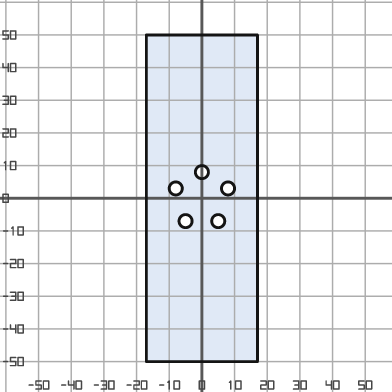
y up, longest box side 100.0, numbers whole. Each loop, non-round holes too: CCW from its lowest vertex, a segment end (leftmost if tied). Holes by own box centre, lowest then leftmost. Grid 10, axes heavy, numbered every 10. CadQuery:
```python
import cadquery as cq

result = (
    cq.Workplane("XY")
    .moveTo(-17.0, -50.0)
    .lineTo(17.0, -50.0)
    .lineTo(17.0, 50.0)
    .lineTo(-17.0, 50.0)
    .close()
    .moveTo(-5.0, -7.0)
    .circle(2.0)
    .moveTo(5.0, -7.0)
    .circle(2.0)
    .moveTo(-8.0, 3.0)
    .circle(2.0)
    .moveTo(8.0, 3.0)
    .circle(2.0)
    .moveTo(0.0, 8.0)
    .circle(2.0)
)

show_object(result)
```